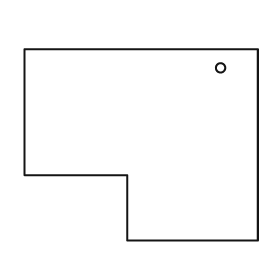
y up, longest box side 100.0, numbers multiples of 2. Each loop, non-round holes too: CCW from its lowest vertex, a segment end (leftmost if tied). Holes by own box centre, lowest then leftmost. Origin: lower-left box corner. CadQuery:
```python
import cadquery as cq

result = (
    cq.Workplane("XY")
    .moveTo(44.0, 0.0)
    .lineTo(100.0, 0.0)
    .lineTo(100.0, 82.0)
    .lineTo(0.0, 82.0)
    .lineTo(0.0, 28.0)
    .lineTo(44.0, 28.0)
    .close()
    .moveTo(84.0, 74.0)
    .circle(2.0)
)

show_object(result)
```